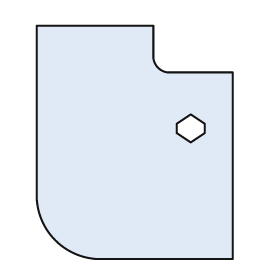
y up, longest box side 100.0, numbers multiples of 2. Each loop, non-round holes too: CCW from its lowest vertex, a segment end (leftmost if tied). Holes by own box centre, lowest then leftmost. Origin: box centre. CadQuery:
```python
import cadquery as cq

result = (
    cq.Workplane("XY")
    .moveTo(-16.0, -50.0)
    .lineTo(42.0, -50.0)
    .lineTo(42.0, 30.0)
    .lineTo(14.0, 30.0)
    .threePointArc((10.0, 32.0), (8.0, 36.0))
    .lineTo(8.0, 50.0)
    .lineTo(-42.0, 50.0)
    .lineTo(-42.0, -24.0)
    .threePointArc((-34.0, -42.0), (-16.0, -50.0))
    .close()
    .moveTo(24.0, 0.0)
    .lineTo(30.0, 4.0)
    .lineTo(30.0, 8.0)
    .lineTo(24.0, 12.0)
    .lineTo(18.0, 8.0)
    .lineTo(18.0, 4.0)
    .close()
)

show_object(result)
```